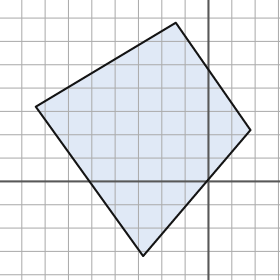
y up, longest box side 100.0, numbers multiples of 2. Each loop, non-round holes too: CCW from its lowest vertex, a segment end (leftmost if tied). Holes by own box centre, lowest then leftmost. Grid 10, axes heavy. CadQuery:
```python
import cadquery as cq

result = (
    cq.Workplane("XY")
    .moveTo(-28.0, -32.0)
    .lineTo(18.0, 22.0)
    .lineTo(-14.0, 68.0)
    .lineTo(-74.0, 32.0)
    .close()
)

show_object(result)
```